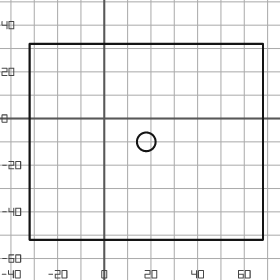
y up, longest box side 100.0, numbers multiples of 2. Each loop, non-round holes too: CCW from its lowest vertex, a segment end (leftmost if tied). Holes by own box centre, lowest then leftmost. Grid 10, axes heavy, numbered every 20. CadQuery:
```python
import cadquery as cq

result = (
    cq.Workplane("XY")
    .moveTo(-32.0, -52.0)
    .lineTo(68.0, -52.0)
    .lineTo(68.0, 32.0)
    .lineTo(-32.0, 32.0)
    .close()
    .moveTo(18.0, -10.0)
    .circle(4.0)
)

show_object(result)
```